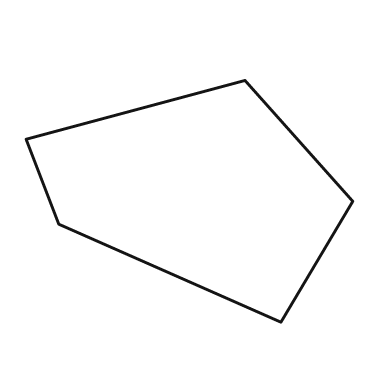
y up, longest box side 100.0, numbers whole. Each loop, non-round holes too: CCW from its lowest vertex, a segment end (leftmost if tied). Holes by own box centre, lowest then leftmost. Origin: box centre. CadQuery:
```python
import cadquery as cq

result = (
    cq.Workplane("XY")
    .moveTo(28.0, -37.0)
    .lineTo(50.0, 0.0)
    .lineTo(17.0, 37.0)
    .lineTo(-50.0, 19.0)
    .lineTo(-40.0, -7.0)
    .close()
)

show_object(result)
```